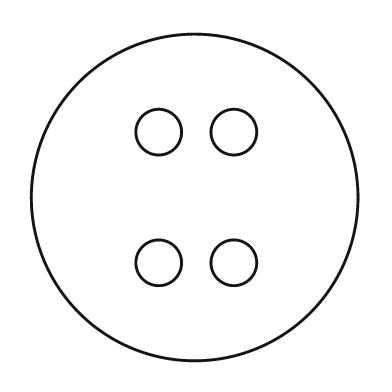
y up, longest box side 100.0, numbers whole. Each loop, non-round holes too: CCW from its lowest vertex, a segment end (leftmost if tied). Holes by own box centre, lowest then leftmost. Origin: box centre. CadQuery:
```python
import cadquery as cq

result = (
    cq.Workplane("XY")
    .moveTo(0.0, 0.0)
    .circle(50.0)
    .moveTo(-11.0, -20.0)
    .circle(7.0)
    .moveTo(12.0, -20.0)
    .circle(7.0)
    .moveTo(-11.0, 20.0)
    .circle(7.0)
    .moveTo(12.0, 20.0)
    .circle(7.0)
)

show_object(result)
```